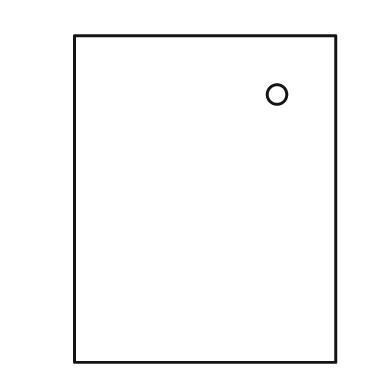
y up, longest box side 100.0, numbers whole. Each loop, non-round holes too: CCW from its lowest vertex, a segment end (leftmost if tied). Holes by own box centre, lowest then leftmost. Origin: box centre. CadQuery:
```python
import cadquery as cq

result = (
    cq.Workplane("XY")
    .moveTo(-40.0, -50.0)
    .lineTo(40.0, -50.0)
    .lineTo(40.0, 50.0)
    .lineTo(-40.0, 50.0)
    .close()
    .moveTo(22.0, 32.0)
    .circle(3.0)
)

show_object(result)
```